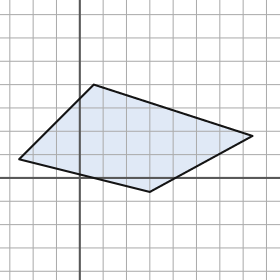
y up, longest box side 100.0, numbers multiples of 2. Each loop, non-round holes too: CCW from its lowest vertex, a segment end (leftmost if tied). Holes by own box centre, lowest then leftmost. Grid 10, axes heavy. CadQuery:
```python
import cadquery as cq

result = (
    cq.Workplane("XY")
    .moveTo(30.0, -6.0)
    .lineTo(74.0, 18.0)
    .lineTo(6.0, 40.0)
    .lineTo(-26.0, 8.0)
    .close()
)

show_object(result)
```